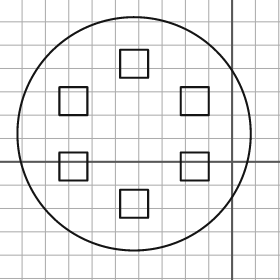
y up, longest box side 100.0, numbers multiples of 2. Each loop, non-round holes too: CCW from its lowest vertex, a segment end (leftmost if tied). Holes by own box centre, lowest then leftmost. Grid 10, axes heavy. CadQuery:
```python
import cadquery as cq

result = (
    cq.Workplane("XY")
    .moveTo(-42.0, 12.0)
    .circle(50.0)
    .moveTo(-48.0, -24.0)
    .lineTo(-36.0, -24.0)
    .lineTo(-36.0, -12.0)
    .lineTo(-48.0, -12.0)
    .close()
    .moveTo(-74.0, -8.0)
    .lineTo(-62.0, -8.0)
    .lineTo(-62.0, 4.0)
    .lineTo(-74.0, 4.0)
    .close()
    .moveTo(-22.0, -8.0)
    .lineTo(-10.0, -8.0)
    .lineTo(-10.0, 4.0)
    .lineTo(-22.0, 4.0)
    .close()
    .moveTo(-74.0, 20.0)
    .lineTo(-62.0, 20.0)
    .lineTo(-62.0, 32.0)
    .lineTo(-74.0, 32.0)
    .close()
    .moveTo(-22.0, 20.0)
    .lineTo(-10.0, 20.0)
    .lineTo(-10.0, 32.0)
    .lineTo(-22.0, 32.0)
    .close()
    .moveTo(-48.0, 36.0)
    .lineTo(-36.0, 36.0)
    .lineTo(-36.0, 48.0)
    .lineTo(-48.0, 48.0)
    .close()
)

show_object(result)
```